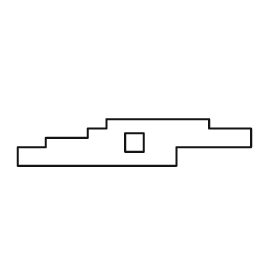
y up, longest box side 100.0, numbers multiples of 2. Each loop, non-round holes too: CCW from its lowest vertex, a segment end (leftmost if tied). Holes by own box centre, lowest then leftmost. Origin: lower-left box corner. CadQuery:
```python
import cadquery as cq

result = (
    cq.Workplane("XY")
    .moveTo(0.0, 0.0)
    .lineTo(68.0, 0.0)
    .lineTo(68.0, 8.0)
    .lineTo(100.0, 8.0)
    .lineTo(100.0, 16.0)
    .lineTo(82.0, 16.0)
    .lineTo(82.0, 20.0)
    .lineTo(38.0, 20.0)
    .lineTo(38.0, 16.0)
    .lineTo(30.0, 16.0)
    .lineTo(30.0, 12.0)
    .lineTo(12.0, 12.0)
    .lineTo(12.0, 8.0)
    .lineTo(0.0, 8.0)
    .close()
    .moveTo(46.0, 6.0)
    .lineTo(54.0, 6.0)
    .lineTo(54.0, 14.0)
    .lineTo(46.0, 14.0)
    .close()
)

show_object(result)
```